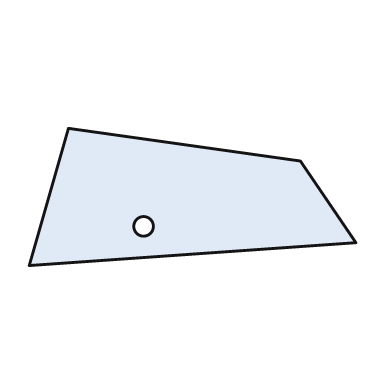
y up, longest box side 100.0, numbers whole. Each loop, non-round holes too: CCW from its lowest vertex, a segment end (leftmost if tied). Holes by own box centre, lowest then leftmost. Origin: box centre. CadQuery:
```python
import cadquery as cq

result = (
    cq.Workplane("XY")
    .moveTo(-50.0, -21.0)
    .lineTo(50.0, -14.0)
    .lineTo(33.0, 11.0)
    .lineTo(-38.0, 21.0)
    .close()
    .moveTo(-15.0, -9.0)
    .circle(3.0)
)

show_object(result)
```